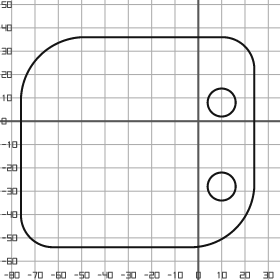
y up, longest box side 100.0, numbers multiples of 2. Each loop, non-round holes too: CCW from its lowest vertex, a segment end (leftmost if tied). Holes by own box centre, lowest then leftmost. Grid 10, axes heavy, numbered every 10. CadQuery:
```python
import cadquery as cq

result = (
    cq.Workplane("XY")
    .moveTo(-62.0, -54.0)
    .lineTo(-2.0, -54.0)
    .threePointArc((16.0, -46.0), (24.0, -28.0))
    .lineTo(24.0, 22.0)
    .threePointArc((20.0, 32.0), (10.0, 36.0))
    .lineTo(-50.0, 36.0)
    .threePointArc((-68.0, 28.0), (-76.0, 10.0))
    .lineTo(-76.0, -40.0)
    .threePointArc((-72.0, -50.0), (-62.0, -54.0))
    .close()
    .moveTo(10.0, -28.0)
    .circle(6.0)
    .moveTo(10.0, 8.0)
    .circle(6.0)
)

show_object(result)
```